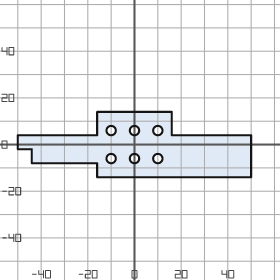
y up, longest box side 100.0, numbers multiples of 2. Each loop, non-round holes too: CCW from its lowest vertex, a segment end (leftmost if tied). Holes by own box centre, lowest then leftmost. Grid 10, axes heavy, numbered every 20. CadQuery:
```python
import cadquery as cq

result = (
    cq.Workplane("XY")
    .moveTo(-16.0, -14.0)
    .lineTo(50.0, -14.0)
    .lineTo(50.0, 4.0)
    .lineTo(16.0, 4.0)
    .lineTo(16.0, 14.0)
    .lineTo(-16.0, 14.0)
    .lineTo(-16.0, 4.0)
    .lineTo(-50.0, 4.0)
    .lineTo(-50.0, -2.0)
    .lineTo(-44.0, -2.0)
    .lineTo(-44.0, -8.0)
    .lineTo(-16.0, -8.0)
    .close()
    .moveTo(-10.0, -6.0)
    .circle(2.0)
    .moveTo(0.0, -6.0)
    .circle(2.0)
    .moveTo(10.0, -6.0)
    .circle(2.0)
    .moveTo(-10.0, 6.0)
    .circle(2.0)
    .moveTo(0.0, 6.0)
    .circle(2.0)
    .moveTo(10.0, 6.0)
    .circle(2.0)
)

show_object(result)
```